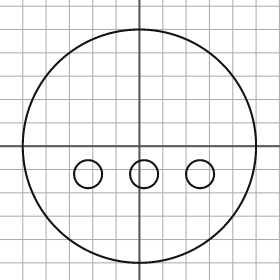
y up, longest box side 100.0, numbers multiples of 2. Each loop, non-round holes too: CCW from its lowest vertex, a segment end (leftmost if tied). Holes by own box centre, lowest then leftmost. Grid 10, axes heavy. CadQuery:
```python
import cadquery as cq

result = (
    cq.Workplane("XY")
    .moveTo(0.0, 0.0)
    .circle(50.0)
    .moveTo(-22.0, -12.0)
    .circle(6.0)
    .moveTo(2.0, -12.0)
    .circle(6.0)
    .moveTo(26.0, -12.0)
    .circle(6.0)
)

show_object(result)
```